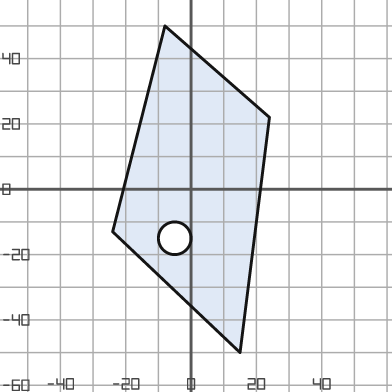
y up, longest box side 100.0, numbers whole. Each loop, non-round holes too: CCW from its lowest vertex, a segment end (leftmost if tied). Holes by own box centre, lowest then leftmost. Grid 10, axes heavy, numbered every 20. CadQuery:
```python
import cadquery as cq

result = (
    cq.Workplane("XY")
    .moveTo(15.0, -50.0)
    .lineTo(24.0, 22.0)
    .lineTo(-8.0, 50.0)
    .lineTo(-24.0, -13.0)
    .close()
    .moveTo(-5.0, -15.0)
    .circle(5.0)
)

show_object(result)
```